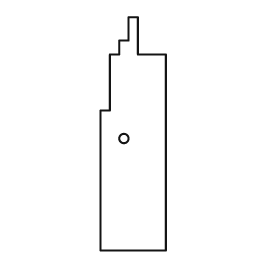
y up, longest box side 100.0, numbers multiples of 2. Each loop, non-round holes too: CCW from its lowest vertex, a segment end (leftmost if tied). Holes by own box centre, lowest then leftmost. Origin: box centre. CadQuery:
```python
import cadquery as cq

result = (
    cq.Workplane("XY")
    .moveTo(-14.0, -50.0)
    .lineTo(14.0, -50.0)
    .lineTo(14.0, 34.0)
    .lineTo(2.0, 34.0)
    .lineTo(2.0, 50.0)
    .lineTo(-2.0, 50.0)
    .lineTo(-2.0, 40.0)
    .lineTo(-6.0, 40.0)
    .lineTo(-6.0, 34.0)
    .lineTo(-10.0, 34.0)
    .lineTo(-10.0, 10.0)
    .lineTo(-14.0, 10.0)
    .close()
    .moveTo(-4.0, -2.0)
    .circle(2.0)
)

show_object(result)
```